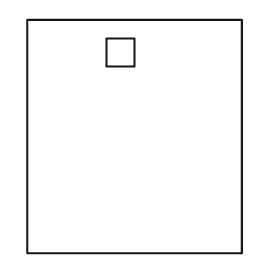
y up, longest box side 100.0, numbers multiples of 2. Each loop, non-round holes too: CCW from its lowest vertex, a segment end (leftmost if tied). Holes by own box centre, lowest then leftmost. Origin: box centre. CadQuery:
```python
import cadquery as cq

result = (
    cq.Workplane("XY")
    .moveTo(-46.0, -50.0)
    .lineTo(46.0, -50.0)
    .lineTo(46.0, 50.0)
    .lineTo(-46.0, 50.0)
    .close()
    .moveTo(-12.0, 30.0)
    .lineTo(0.0, 30.0)
    .lineTo(0.0, 42.0)
    .lineTo(-12.0, 42.0)
    .close()
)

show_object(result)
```